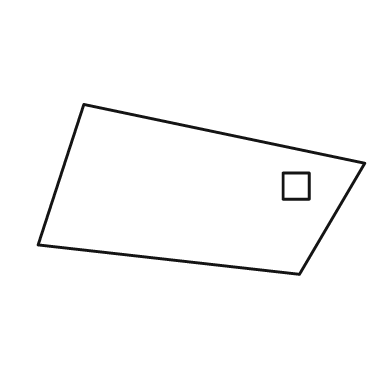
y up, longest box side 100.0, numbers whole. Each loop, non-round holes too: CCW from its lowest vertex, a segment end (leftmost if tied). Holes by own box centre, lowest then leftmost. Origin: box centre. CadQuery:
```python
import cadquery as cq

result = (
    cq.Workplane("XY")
    .moveTo(30.0, -26.0)
    .lineTo(50.0, 8.0)
    .lineTo(-36.0, 26.0)
    .lineTo(-50.0, -17.0)
    .close()
    .moveTo(25.0, -3.0)
    .lineTo(33.0, -3.0)
    .lineTo(33.0, 5.0)
    .lineTo(25.0, 5.0)
    .close()
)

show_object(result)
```